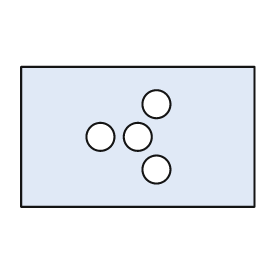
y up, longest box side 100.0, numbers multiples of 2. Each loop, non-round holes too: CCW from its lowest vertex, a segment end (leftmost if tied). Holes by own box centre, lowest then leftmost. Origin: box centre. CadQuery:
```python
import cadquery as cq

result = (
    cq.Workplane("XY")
    .moveTo(-50.0, -30.0)
    .lineTo(50.0, -30.0)
    .lineTo(50.0, 30.0)
    .lineTo(-50.0, 30.0)
    .close()
    .moveTo(8.0, -14.0)
    .circle(6.0)
    .moveTo(-16.0, 0.0)
    .circle(6.0)
    .moveTo(0.0, 0.0)
    .circle(6.0)
    .moveTo(8.0, 14.0)
    .circle(6.0)
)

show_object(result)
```